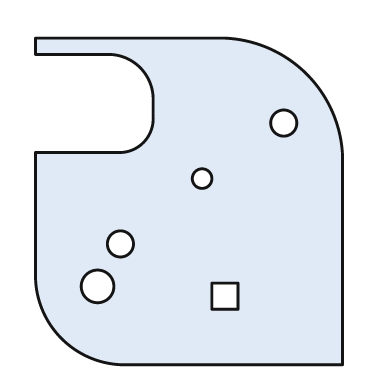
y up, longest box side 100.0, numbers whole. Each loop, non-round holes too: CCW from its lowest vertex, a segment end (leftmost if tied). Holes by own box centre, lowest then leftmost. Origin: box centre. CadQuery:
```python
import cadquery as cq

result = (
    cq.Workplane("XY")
    .moveTo(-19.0, -50.0)
    .lineTo(47.0, -50.0)
    .lineTo(47.0, 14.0)
    .threePointArc((36.0, 39.0), (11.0, 50.0))
    .lineTo(-47.0, 50.0)
    .lineTo(-47.0, 45.0)
    .lineTo(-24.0, 45.0)
    .threePointArc((-15.0, 41.0), (-11.0, 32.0))
    .lineTo(-11.0, 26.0)
    .threePointArc((-14.0, 18.0), (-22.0, 15.0))
    .lineTo(-47.0, 15.0)
    .lineTo(-47.0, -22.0)
    .threePointArc((-39.0, -42.0), (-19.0, -50.0))
    .close()
    .moveTo(7.0, -33.0)
    .lineTo(15.0, -33.0)
    .lineTo(15.0, -25.0)
    .lineTo(7.0, -25.0)
    .close()
    .moveTo(-28.0, -26.0)
    .circle(5.0)
    .moveTo(-21.0, -13.0)
    .circle(4.0)
    .moveTo(4.0, 7.0)
    .circle(3.0)
    .moveTo(29.0, 24.0)
    .circle(4.0)
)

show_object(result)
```